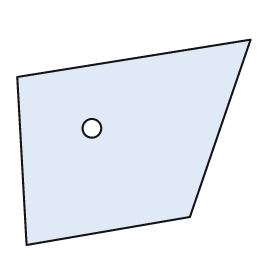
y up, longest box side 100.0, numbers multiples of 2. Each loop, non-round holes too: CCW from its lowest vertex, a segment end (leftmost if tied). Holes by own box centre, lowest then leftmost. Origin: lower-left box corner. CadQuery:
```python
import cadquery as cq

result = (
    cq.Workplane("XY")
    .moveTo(4.0, 0.0)
    .lineTo(74.0, 12.0)
    .lineTo(100.0, 88.0)
    .lineTo(0.0, 72.0)
    .close()
    .moveTo(32.0, 50.0)
    .circle(4.0)
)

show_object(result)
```